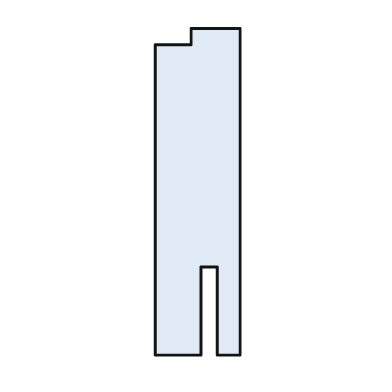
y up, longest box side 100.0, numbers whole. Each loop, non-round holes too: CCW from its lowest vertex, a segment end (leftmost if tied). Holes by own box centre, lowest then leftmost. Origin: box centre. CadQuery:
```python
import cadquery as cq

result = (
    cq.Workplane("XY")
    .moveTo(-13.0, -50.0)
    .lineTo(1.0, -50.0)
    .lineTo(1.0, -23.0)
    .lineTo(6.0, -23.0)
    .lineTo(6.0, -50.0)
    .lineTo(13.0, -50.0)
    .lineTo(13.0, 50.0)
    .lineTo(-2.0, 50.0)
    .lineTo(-2.0, 45.0)
    .lineTo(-13.0, 45.0)
    .close()
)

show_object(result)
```